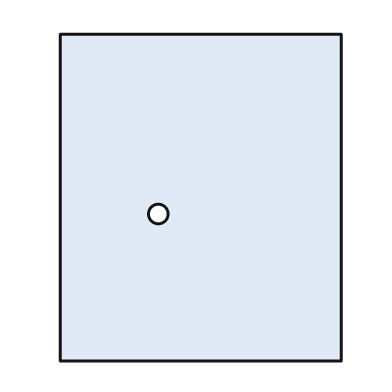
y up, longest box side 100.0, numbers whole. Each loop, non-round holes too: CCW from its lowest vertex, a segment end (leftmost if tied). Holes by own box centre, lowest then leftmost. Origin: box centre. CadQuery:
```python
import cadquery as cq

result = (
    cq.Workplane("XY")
    .moveTo(-43.0, -50.0)
    .lineTo(43.0, -50.0)
    .lineTo(43.0, 50.0)
    .lineTo(-43.0, 50.0)
    .close()
    .moveTo(-13.0, -5.0)
    .circle(3.0)
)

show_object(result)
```